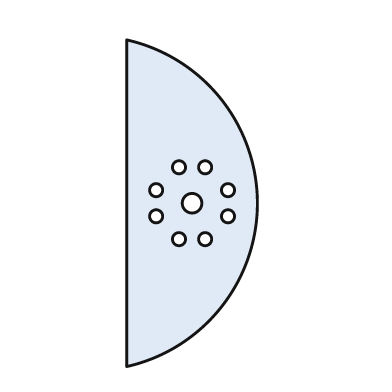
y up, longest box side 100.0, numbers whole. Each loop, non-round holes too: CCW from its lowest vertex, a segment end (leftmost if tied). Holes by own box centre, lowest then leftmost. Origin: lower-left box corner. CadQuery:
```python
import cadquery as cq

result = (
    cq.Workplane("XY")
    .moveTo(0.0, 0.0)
    .threePointArc((40.0, 50.0), (0.0, 100.0))
    .close()
    .moveTo(16.0, 39.0)
    .circle(2.0)
    .moveTo(24.0, 39.0)
    .circle(2.0)
    .moveTo(9.0, 46.0)
    .circle(2.0)
    .moveTo(31.0, 46.0)
    .circle(2.0)
    .moveTo(20.0, 50.0)
    .circle(3.0)
    .moveTo(9.0, 54.0)
    .circle(2.0)
    .moveTo(31.0, 54.0)
    .circle(2.0)
    .moveTo(16.0, 61.0)
    .circle(2.0)
    .moveTo(24.0, 61.0)
    .circle(2.0)
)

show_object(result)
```